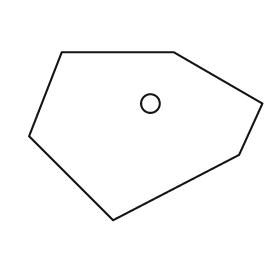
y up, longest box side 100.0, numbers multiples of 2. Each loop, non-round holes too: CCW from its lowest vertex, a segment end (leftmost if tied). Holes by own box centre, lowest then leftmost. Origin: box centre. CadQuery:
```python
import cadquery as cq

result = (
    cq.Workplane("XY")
    .moveTo(-14.0, -36.0)
    .lineTo(40.0, -8.0)
    .lineTo(50.0, 14.0)
    .lineTo(12.0, 36.0)
    .lineTo(-36.0, 36.0)
    .lineTo(-50.0, 0.0)
    .close()
    .moveTo(2.0, 14.0)
    .circle(4.0)
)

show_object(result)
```